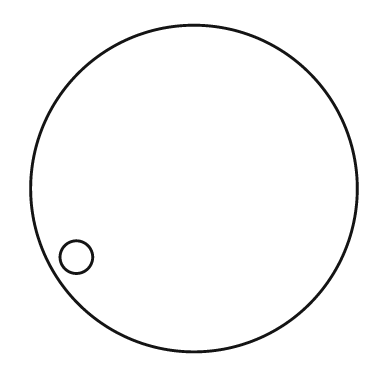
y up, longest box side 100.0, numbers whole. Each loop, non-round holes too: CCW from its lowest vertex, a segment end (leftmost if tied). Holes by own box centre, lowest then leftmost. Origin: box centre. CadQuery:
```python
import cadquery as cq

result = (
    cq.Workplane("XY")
    .moveTo(0.0, 0.0)
    .circle(50.0)
    .moveTo(-36.0, -21.0)
    .circle(5.0)
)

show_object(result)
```